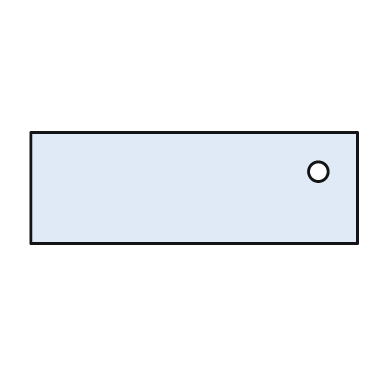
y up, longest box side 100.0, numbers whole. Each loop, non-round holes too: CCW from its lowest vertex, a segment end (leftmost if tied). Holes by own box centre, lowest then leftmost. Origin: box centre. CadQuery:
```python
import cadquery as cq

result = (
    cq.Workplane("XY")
    .moveTo(-50.0, -17.0)
    .lineTo(50.0, -17.0)
    .lineTo(50.0, 17.0)
    .lineTo(-50.0, 17.0)
    .close()
    .moveTo(38.0, 5.0)
    .circle(3.0)
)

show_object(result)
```